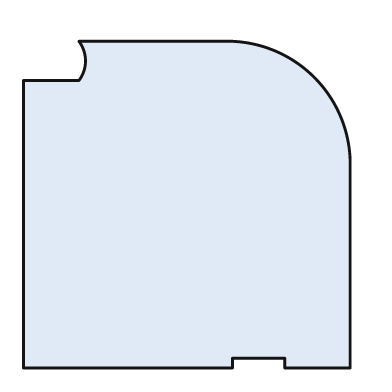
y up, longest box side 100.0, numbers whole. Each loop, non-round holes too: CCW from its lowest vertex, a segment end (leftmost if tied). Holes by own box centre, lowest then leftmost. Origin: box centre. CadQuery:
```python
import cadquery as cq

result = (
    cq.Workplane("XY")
    .moveTo(-50.0, -50.0)
    .lineTo(14.0, -50.0)
    .lineTo(14.0, -47.0)
    .lineTo(30.0, -47.0)
    .lineTo(30.0, -50.0)
    .lineTo(50.0, -50.0)
    .lineTo(50.0, 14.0)
    .threePointArc((39.0, 39.0), (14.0, 50.0))
    .lineTo(-33.0, 50.0)
    .threePointArc((-31.0, 44.0), (-33.0, 38.0))
    .lineTo(-50.0, 38.0)
    .close()
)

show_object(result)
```